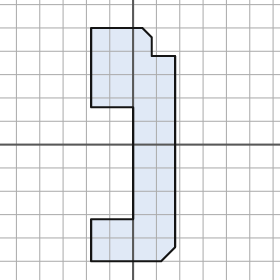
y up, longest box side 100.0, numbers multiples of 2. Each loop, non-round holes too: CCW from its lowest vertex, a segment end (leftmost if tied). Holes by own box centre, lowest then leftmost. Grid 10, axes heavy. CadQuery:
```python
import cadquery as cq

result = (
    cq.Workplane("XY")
    .moveTo(-18.0, -50.0)
    .lineTo(12.0, -50.0)
    .lineTo(18.0, -44.0)
    .lineTo(18.0, 38.0)
    .lineTo(8.0, 38.0)
    .lineTo(8.0, 46.0)
    .lineTo(4.0, 50.0)
    .lineTo(-18.0, 50.0)
    .lineTo(-18.0, 16.0)
    .lineTo(0.0, 16.0)
    .lineTo(0.0, -32.0)
    .lineTo(-18.0, -32.0)
    .close()
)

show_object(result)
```